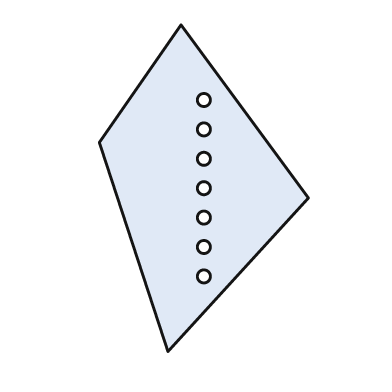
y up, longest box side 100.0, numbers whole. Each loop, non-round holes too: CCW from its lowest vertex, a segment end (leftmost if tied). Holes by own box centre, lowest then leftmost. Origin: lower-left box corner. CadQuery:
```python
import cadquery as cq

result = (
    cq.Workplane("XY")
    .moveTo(21.0, 0.0)
    .lineTo(64.0, 47.0)
    .lineTo(25.0, 100.0)
    .lineTo(0.0, 64.0)
    .close()
    .moveTo(32.0, 23.0)
    .circle(2.0)
    .moveTo(32.0, 32.0)
    .circle(2.0)
    .moveTo(32.0, 41.0)
    .circle(2.0)
    .moveTo(32.0, 50.0)
    .circle(2.0)
    .moveTo(32.0, 59.0)
    .circle(2.0)
    .moveTo(32.0, 68.0)
    .circle(2.0)
    .moveTo(32.0, 77.0)
    .circle(2.0)
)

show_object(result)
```